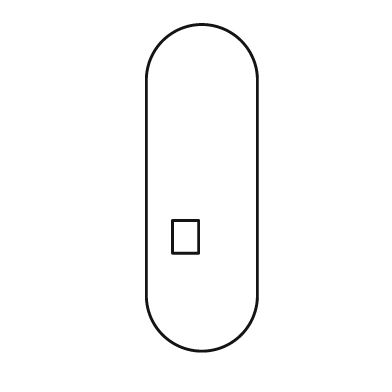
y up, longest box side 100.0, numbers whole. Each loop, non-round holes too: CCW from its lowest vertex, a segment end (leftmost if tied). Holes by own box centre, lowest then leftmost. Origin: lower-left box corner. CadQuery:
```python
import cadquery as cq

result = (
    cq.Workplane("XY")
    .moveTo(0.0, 17.0)
    .threePointArc((17.0, 0.0), (34.0, 17.0))
    .lineTo(34.0, 83.0)
    .threePointArc((17.0, 100.0), (0.0, 83.0))
    .close()
    .moveTo(8.0, 30.0)
    .lineTo(16.0, 30.0)
    .lineTo(16.0, 40.0)
    .lineTo(8.0, 40.0)
    .close()
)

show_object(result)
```